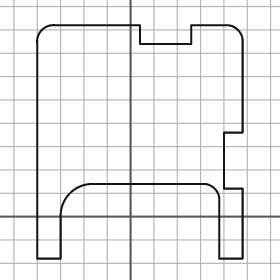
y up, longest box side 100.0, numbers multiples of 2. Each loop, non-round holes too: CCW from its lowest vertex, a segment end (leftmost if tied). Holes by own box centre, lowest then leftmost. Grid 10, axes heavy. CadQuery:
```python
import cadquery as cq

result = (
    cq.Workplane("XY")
    .moveTo(-40.0, -18.0)
    .lineTo(-30.0, -18.0)
    .lineTo(-30.0, 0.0)
    .threePointArc((-26.0, 10.0), (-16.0, 14.0))
    .lineTo(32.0, 14.0)
    .threePointArc((36.0, 12.0), (38.0, 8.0))
    .lineTo(38.0, -18.0)
    .lineTo(48.0, -18.0)
    .lineTo(48.0, 12.0)
    .lineTo(40.0, 12.0)
    .lineTo(40.0, 36.0)
    .lineTo(48.0, 36.0)
    .lineTo(48.0, 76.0)
    .threePointArc((46.0, 80.0), (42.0, 82.0))
    .lineTo(26.0, 82.0)
    .lineTo(26.0, 74.0)
    .lineTo(4.0, 74.0)
    .lineTo(4.0, 82.0)
    .lineTo(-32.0, 82.0)
    .threePointArc((-38.0, 80.0), (-40.0, 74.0))
    .close()
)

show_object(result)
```